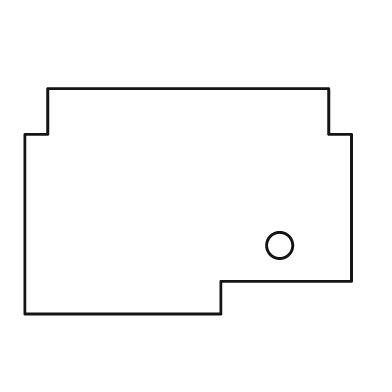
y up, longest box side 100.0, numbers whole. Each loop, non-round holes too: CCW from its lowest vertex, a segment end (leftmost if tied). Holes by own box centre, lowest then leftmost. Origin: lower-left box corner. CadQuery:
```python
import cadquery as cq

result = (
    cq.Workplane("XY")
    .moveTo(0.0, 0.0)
    .lineTo(60.0, 0.0)
    .lineTo(60.0, 10.0)
    .lineTo(100.0, 10.0)
    .lineTo(100.0, 55.0)
    .lineTo(93.0, 55.0)
    .lineTo(93.0, 69.0)
    .lineTo(7.0, 69.0)
    .lineTo(7.0, 55.0)
    .lineTo(0.0, 55.0)
    .close()
    .moveTo(78.0, 21.0)
    .circle(4.0)
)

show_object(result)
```